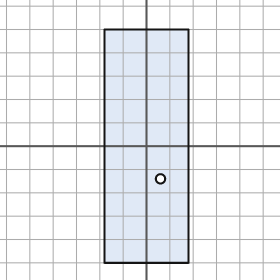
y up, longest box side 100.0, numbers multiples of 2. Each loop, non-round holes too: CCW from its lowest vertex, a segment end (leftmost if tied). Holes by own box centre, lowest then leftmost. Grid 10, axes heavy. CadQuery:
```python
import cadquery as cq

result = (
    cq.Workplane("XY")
    .moveTo(-18.0, -50.0)
    .lineTo(18.0, -50.0)
    .lineTo(18.0, 50.0)
    .lineTo(-18.0, 50.0)
    .close()
    .moveTo(6.0, -14.0)
    .circle(2.0)
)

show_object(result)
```